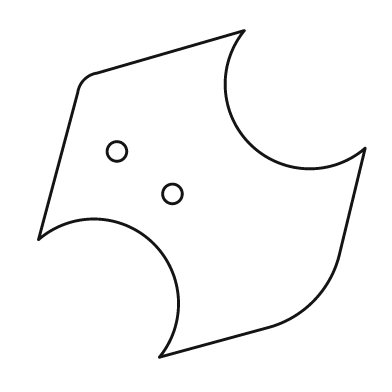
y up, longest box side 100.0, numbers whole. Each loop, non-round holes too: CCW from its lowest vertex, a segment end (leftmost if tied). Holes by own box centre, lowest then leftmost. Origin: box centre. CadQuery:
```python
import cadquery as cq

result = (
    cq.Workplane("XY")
    .moveTo(-13.0, -50.0)
    .lineTo(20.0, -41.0)
    .threePointArc((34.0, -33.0), (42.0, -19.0))
    .lineTo(50.0, 14.0)
    .threePointArc((15.0, 15.0), (13.0, 50.0))
    .lineTo(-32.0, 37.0)
    .threePointArc((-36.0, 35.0), (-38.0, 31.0))
    .lineTo(-50.0, -14.0)
    .threePointArc((-15.0, -15.0), (-13.0, -50.0))
    .close()
    .moveTo(-9.0, 0.0)
    .circle(3.0)
    .moveTo(-26.0, 13.0)
    .circle(3.0)
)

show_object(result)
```